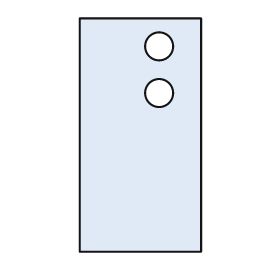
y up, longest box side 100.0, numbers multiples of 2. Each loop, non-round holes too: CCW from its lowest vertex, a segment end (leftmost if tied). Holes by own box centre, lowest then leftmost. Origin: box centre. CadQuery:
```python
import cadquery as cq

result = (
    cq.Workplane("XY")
    .moveTo(-26.0, -50.0)
    .lineTo(26.0, -50.0)
    .lineTo(26.0, 50.0)
    .lineTo(-26.0, 50.0)
    .close()
    .moveTo(8.0, 18.0)
    .circle(6.0)
    .moveTo(8.0, 38.0)
    .circle(6.0)
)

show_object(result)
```